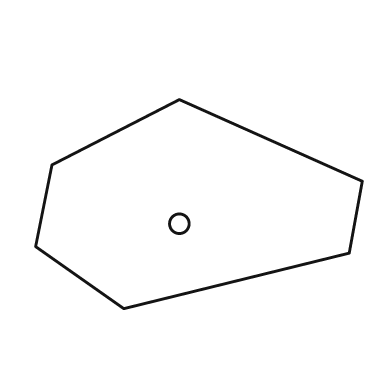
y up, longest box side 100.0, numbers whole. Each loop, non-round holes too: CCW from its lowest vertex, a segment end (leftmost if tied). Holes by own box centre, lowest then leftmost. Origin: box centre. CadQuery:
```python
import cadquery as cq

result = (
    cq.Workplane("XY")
    .moveTo(-23.0, -32.0)
    .lineTo(46.0, -15.0)
    .lineTo(50.0, 7.0)
    .lineTo(-6.0, 32.0)
    .lineTo(-45.0, 12.0)
    .lineTo(-50.0, -13.0)
    .close()
    .moveTo(-6.0, -6.0)
    .circle(3.0)
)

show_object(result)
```